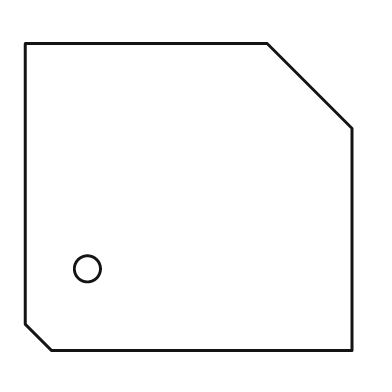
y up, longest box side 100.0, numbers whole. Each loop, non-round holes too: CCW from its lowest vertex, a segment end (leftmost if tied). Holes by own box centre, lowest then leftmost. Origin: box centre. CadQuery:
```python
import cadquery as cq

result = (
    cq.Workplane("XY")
    .moveTo(-42.0, -47.0)
    .lineTo(50.0, -47.0)
    .lineTo(50.0, 21.0)
    .lineTo(24.0, 47.0)
    .lineTo(-50.0, 47.0)
    .lineTo(-50.0, -39.0)
    .close()
    .moveTo(-31.0, -22.0)
    .circle(4.0)
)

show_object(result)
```